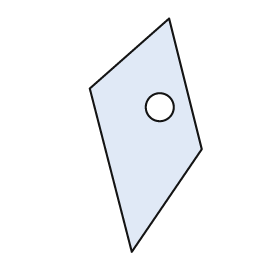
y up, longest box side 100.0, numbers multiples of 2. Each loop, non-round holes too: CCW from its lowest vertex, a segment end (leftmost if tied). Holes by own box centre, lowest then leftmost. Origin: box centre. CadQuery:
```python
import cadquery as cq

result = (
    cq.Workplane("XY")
    .moveTo(-6.0, -50.0)
    .lineTo(24.0, -6.0)
    .lineTo(10.0, 50.0)
    .lineTo(-24.0, 20.0)
    .close()
    .moveTo(6.0, 12.0)
    .circle(6.0)
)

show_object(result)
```